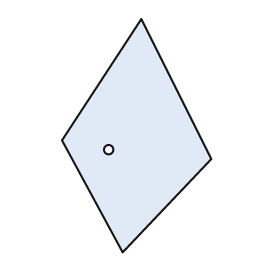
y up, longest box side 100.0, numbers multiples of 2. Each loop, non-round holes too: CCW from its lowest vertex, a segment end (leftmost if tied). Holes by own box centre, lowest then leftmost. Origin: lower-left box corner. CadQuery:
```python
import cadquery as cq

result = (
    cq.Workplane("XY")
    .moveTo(26.0, 0.0)
    .lineTo(64.0, 40.0)
    .lineTo(34.0, 100.0)
    .lineTo(0.0, 48.0)
    .close()
    .moveTo(20.0, 44.0)
    .circle(2.0)
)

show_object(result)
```